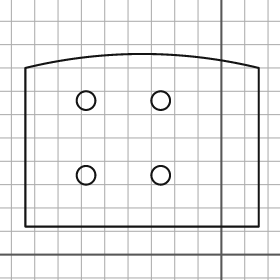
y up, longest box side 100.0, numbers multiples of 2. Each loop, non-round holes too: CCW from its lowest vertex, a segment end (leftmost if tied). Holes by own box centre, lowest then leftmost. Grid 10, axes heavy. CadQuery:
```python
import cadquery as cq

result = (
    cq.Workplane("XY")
    .moveTo(-84.0, 12.0)
    .lineTo(16.0, 12.0)
    .lineTo(16.0, 80.0)
    .threePointArc((-34.0, 86.0), (-84.0, 80.0))
    .close()
    .moveTo(-58.0, 34.0)
    .circle(4.0)
    .moveTo(-26.0, 34.0)
    .circle(4.0)
    .moveTo(-58.0, 66.0)
    .circle(4.0)
    .moveTo(-26.0, 66.0)
    .circle(4.0)
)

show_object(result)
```